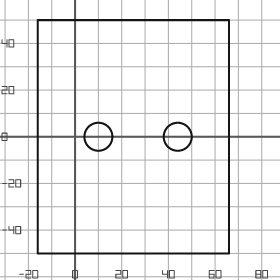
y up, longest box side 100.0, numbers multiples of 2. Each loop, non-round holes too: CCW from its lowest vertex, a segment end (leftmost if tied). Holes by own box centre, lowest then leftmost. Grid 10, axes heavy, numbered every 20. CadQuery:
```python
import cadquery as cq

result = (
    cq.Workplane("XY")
    .moveTo(-16.0, -50.0)
    .lineTo(66.0, -50.0)
    .lineTo(66.0, 50.0)
    .lineTo(-16.0, 50.0)
    .close()
    .moveTo(10.0, 0.0)
    .circle(6.0)
    .moveTo(44.0, 0.0)
    .circle(6.0)
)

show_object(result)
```